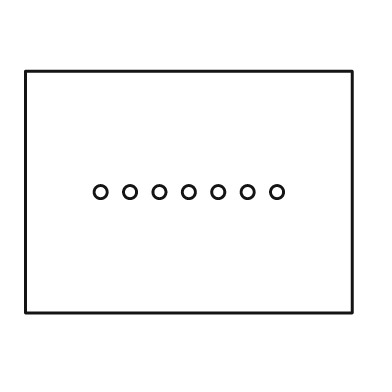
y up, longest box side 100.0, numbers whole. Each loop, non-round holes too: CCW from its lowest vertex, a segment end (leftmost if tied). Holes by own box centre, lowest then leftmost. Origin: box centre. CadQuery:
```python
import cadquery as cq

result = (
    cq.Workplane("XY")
    .moveTo(-50.0, -37.0)
    .lineTo(50.0, -37.0)
    .lineTo(50.0, 37.0)
    .lineTo(-50.0, 37.0)
    .close()
    .moveTo(-27.0, 0.0)
    .circle(2.0)
    .moveTo(-18.0, 0.0)
    .circle(2.0)
    .moveTo(-9.0, 0.0)
    .circle(2.0)
    .moveTo(0.0, 0.0)
    .circle(2.0)
    .moveTo(9.0, 0.0)
    .circle(2.0)
    .moveTo(18.0, 0.0)
    .circle(2.0)
    .moveTo(27.0, 0.0)
    .circle(2.0)
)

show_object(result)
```